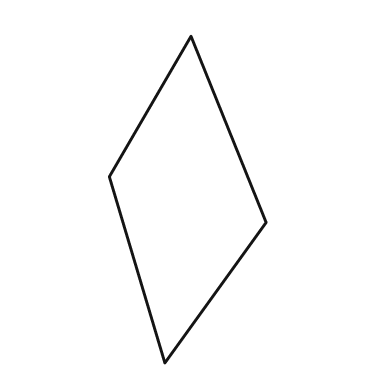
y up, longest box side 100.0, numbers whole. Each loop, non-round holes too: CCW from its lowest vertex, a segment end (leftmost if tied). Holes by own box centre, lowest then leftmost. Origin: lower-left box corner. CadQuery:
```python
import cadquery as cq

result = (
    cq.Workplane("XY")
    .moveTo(17.0, 0.0)
    .lineTo(48.0, 43.0)
    .lineTo(25.0, 100.0)
    .lineTo(0.0, 57.0)
    .close()
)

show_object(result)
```